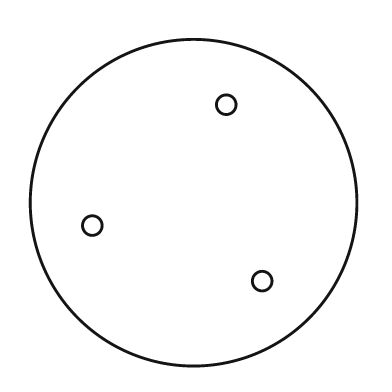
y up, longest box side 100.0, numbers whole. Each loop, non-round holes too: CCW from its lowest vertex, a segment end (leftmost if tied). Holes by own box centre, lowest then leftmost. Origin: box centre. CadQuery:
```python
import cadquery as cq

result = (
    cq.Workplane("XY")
    .moveTo(0.0, 0.0)
    .circle(50.0)
    .moveTo(21.0, -24.0)
    .circle(3.0)
    .moveTo(-31.0, -7.0)
    .circle(3.0)
    .moveTo(10.0, 30.0)
    .circle(3.0)
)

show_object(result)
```